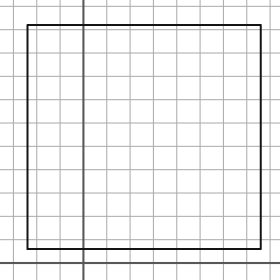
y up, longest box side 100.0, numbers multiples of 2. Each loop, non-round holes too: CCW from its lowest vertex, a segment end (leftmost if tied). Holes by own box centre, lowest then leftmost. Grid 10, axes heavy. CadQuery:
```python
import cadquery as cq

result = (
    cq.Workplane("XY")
    .moveTo(-24.0, 6.0)
    .lineTo(76.0, 6.0)
    .lineTo(76.0, 102.0)
    .lineTo(-24.0, 102.0)
    .close()
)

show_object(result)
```